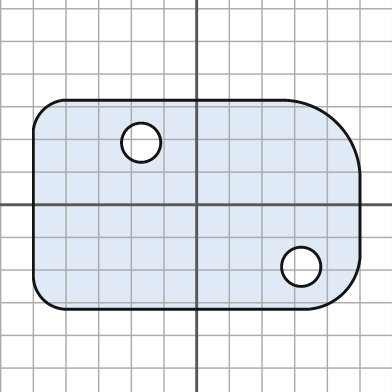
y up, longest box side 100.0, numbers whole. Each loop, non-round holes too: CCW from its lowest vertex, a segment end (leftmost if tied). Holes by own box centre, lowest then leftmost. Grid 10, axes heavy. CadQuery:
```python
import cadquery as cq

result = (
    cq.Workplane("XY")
    .moveTo(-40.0, -32.0)
    .lineTo(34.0, -32.0)
    .threePointArc((45.0, -27.0), (50.0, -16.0))
    .lineTo(50.0, 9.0)
    .threePointArc((43.0, 25.0), (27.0, 32.0))
    .lineTo(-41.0, 32.0)
    .threePointArc((-47.0, 29.0), (-50.0, 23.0))
    .lineTo(-50.0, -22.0)
    .threePointArc((-47.0, -29.0), (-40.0, -32.0))
    .close()
    .moveTo(32.0, -19.0)
    .circle(6.0)
    .moveTo(-17.0, 19.0)
    .circle(6.0)
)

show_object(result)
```